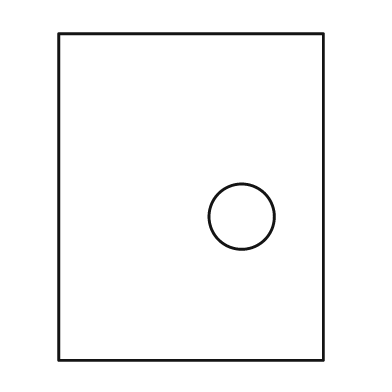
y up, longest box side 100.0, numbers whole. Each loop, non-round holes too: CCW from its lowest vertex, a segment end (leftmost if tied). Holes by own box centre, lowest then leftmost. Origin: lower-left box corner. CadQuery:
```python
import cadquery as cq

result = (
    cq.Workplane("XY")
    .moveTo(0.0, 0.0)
    .lineTo(81.0, 0.0)
    .lineTo(81.0, 100.0)
    .lineTo(0.0, 100.0)
    .close()
    .moveTo(56.0, 44.0)
    .circle(10.0)
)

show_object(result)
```